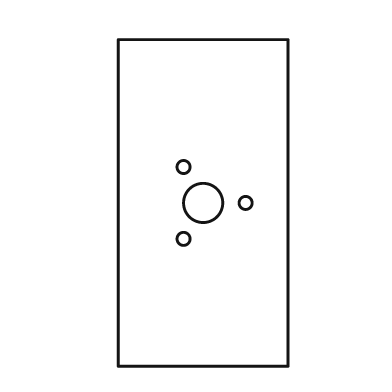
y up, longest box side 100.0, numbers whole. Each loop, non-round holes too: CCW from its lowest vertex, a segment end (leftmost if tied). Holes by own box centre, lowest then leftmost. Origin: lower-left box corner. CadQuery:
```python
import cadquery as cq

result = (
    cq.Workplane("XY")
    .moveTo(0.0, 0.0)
    .lineTo(52.0, 0.0)
    .lineTo(52.0, 100.0)
    .lineTo(0.0, 100.0)
    .close()
    .moveTo(20.0, 39.0)
    .circle(2.0)
    .moveTo(26.0, 50.0)
    .circle(6.0)
    .moveTo(39.0, 50.0)
    .circle(2.0)
    .moveTo(20.0, 61.0)
    .circle(2.0)
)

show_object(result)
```